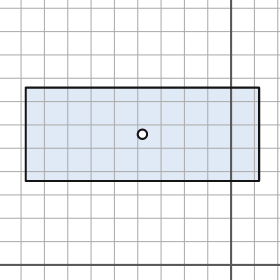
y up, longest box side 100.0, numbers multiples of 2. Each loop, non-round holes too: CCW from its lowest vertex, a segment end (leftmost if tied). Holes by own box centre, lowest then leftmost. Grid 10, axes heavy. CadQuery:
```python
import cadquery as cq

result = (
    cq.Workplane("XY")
    .moveTo(-88.0, 36.0)
    .lineTo(12.0, 36.0)
    .lineTo(12.0, 76.0)
    .lineTo(-88.0, 76.0)
    .close()
    .moveTo(-38.0, 56.0)
    .circle(2.0)
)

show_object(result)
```